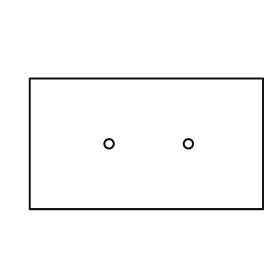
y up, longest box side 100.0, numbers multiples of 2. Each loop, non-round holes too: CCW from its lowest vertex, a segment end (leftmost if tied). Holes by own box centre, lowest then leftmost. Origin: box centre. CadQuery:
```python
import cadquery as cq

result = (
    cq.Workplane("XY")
    .moveTo(-50.0, -28.0)
    .lineTo(50.0, -28.0)
    .lineTo(50.0, 28.0)
    .lineTo(-50.0, 28.0)
    .close()
    .moveTo(-16.0, 0.0)
    .circle(2.0)
    .moveTo(18.0, 0.0)
    .circle(2.0)
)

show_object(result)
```